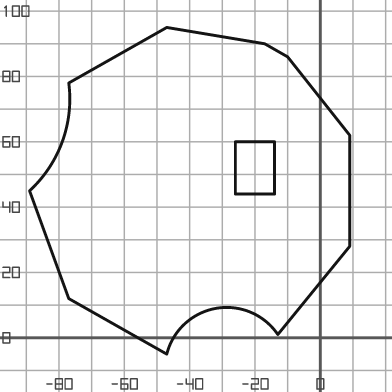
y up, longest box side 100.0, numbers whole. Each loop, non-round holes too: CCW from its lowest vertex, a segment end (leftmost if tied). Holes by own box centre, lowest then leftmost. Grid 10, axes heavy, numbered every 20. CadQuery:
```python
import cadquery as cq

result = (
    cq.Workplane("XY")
    .moveTo(-47.0, -5.0)
    .threePointArc((-32.0, 9.0), (-13.0, 1.0))
    .lineTo(9.0, 28.0)
    .lineTo(9.0, 62.0)
    .lineTo(-10.0, 86.0)
    .lineTo(-17.0, 90.0)
    .lineTo(-47.0, 95.0)
    .lineTo(-77.0, 78.0)
    .threePointArc((-79.0, 60.0), (-89.0, 45.0))
    .lineTo(-77.0, 12.0)
    .close()
    .moveTo(-26.0, 44.0)
    .lineTo(-14.0, 44.0)
    .lineTo(-14.0, 60.0)
    .lineTo(-26.0, 60.0)
    .close()
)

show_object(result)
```